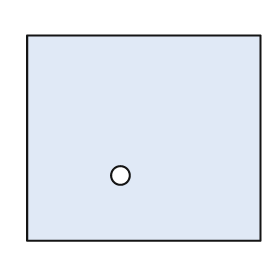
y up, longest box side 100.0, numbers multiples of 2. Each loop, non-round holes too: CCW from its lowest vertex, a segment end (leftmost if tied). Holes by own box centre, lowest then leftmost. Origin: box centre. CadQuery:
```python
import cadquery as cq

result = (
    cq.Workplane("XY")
    .moveTo(-50.0, -44.0)
    .lineTo(50.0, -44.0)
    .lineTo(50.0, 44.0)
    .lineTo(-50.0, 44.0)
    .close()
    .moveTo(-10.0, -16.0)
    .circle(4.0)
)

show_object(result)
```